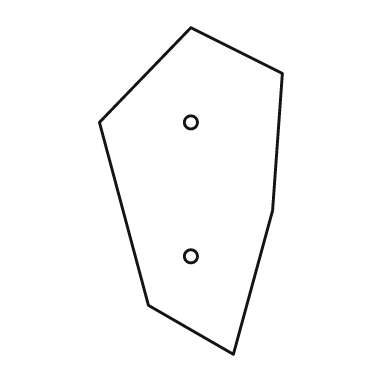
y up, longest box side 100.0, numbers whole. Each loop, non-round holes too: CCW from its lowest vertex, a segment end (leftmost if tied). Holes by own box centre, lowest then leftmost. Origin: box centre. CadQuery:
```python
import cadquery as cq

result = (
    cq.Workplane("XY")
    .moveTo(13.0, -50.0)
    .lineTo(25.0, -6.0)
    .lineTo(28.0, 36.0)
    .lineTo(0.0, 50.0)
    .lineTo(-28.0, 21.0)
    .lineTo(-13.0, -35.0)
    .close()
    .moveTo(0.0, -20.0)
    .circle(2.0)
    .moveTo(0.0, 21.0)
    .circle(2.0)
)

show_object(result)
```